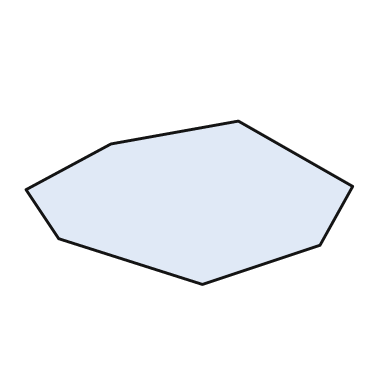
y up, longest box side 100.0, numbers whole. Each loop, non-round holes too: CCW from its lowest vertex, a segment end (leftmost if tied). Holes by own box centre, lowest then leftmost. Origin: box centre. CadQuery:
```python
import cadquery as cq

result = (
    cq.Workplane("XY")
    .moveTo(4.0, -25.0)
    .lineTo(40.0, -13.0)
    .lineTo(50.0, 5.0)
    .lineTo(15.0, 25.0)
    .lineTo(-24.0, 18.0)
    .lineTo(-50.0, 4.0)
    .lineTo(-40.0, -11.0)
    .close()
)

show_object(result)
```